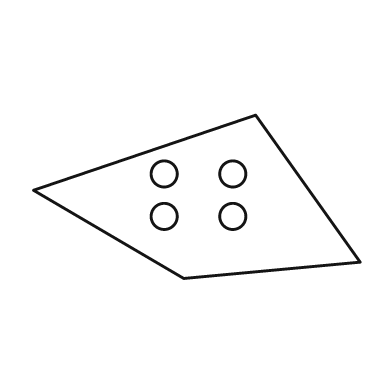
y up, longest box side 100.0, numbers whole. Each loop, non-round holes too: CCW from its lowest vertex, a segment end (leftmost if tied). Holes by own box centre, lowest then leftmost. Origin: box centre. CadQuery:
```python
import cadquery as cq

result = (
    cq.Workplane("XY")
    .moveTo(-4.0, -25.0)
    .lineTo(50.0, -20.0)
    .lineTo(18.0, 25.0)
    .lineTo(-50.0, 2.0)
    .close()
    .moveTo(-10.0, -6.0)
    .circle(4.0)
    .moveTo(11.0, -6.0)
    .circle(4.0)
    .moveTo(-10.0, 7.0)
    .circle(4.0)
    .moveTo(11.0, 7.0)
    .circle(4.0)
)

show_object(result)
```